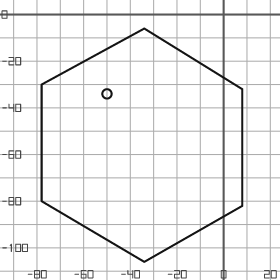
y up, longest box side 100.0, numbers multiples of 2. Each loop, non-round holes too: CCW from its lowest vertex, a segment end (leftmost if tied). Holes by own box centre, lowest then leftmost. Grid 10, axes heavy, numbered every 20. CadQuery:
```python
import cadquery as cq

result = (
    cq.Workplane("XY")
    .moveTo(-34.0, -106.0)
    .lineTo(8.0, -82.0)
    .lineTo(8.0, -32.0)
    .lineTo(-34.0, -6.0)
    .lineTo(-78.0, -30.0)
    .lineTo(-78.0, -80.0)
    .close()
    .moveTo(-50.0, -34.0)
    .circle(2.0)
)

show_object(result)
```